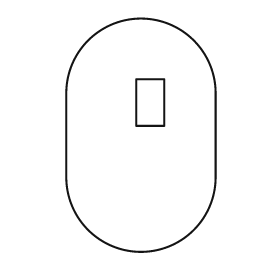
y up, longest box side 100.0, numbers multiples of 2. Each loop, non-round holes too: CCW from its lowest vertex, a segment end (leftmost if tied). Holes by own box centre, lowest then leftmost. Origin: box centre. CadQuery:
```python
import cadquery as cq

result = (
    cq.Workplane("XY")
    .moveTo(-32.0, -18.0)
    .threePointArc((0.0, -50.0), (32.0, -18.0))
    .lineTo(32.0, 18.0)
    .threePointArc((0.0, 50.0), (-32.0, 18.0))
    .close()
    .moveTo(-2.0, 4.0)
    .lineTo(10.0, 4.0)
    .lineTo(10.0, 24.0)
    .lineTo(-2.0, 24.0)
    .close()
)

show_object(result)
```